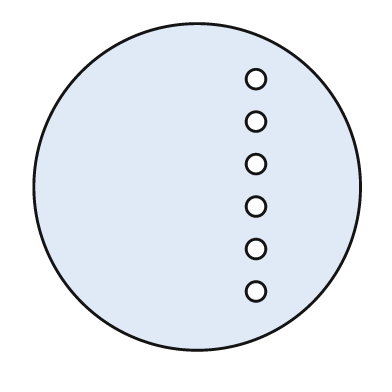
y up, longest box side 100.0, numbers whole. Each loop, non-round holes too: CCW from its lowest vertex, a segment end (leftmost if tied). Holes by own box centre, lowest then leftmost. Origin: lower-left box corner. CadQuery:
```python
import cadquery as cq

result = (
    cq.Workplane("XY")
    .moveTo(50.0, 50.0)
    .circle(50.0)
    .moveTo(68.0, 18.0)
    .circle(3.0)
    .moveTo(68.0, 31.0)
    .circle(3.0)
    .moveTo(68.0, 44.0)
    .circle(3.0)
    .moveTo(68.0, 57.0)
    .circle(3.0)
    .moveTo(68.0, 70.0)
    .circle(3.0)
    .moveTo(68.0, 83.0)
    .circle(3.0)
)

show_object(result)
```